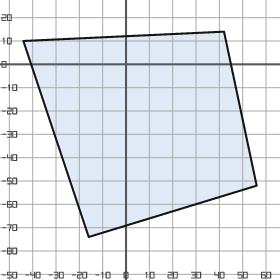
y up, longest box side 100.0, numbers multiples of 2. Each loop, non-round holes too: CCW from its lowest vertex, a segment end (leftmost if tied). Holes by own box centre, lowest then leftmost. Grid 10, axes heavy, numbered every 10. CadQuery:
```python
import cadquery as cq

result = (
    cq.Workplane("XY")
    .moveTo(-16.0, -74.0)
    .lineTo(56.0, -52.0)
    .lineTo(42.0, 14.0)
    .lineTo(-44.0, 10.0)
    .close()
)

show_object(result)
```